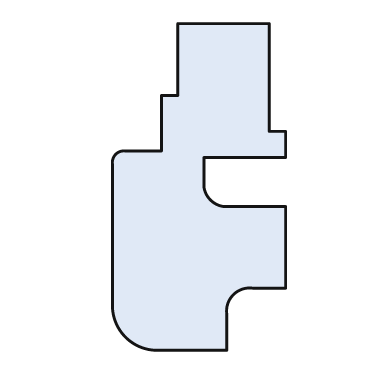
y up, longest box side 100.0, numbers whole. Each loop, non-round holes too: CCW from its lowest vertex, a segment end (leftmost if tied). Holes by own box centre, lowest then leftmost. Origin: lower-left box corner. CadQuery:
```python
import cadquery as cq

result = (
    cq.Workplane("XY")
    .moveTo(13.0, 0.0)
    .lineTo(35.0, 0.0)
    .lineTo(35.0, 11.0)
    .threePointArc((37.0, 17.0), (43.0, 19.0))
    .lineTo(53.0, 19.0)
    .lineTo(53.0, 44.0)
    .lineTo(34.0, 44.0)
    .threePointArc((30.0, 46.0), (28.0, 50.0))
    .lineTo(28.0, 59.0)
    .lineTo(53.0, 59.0)
    .lineTo(53.0, 67.0)
    .lineTo(48.0, 67.0)
    .lineTo(48.0, 100.0)
    .lineTo(20.0, 100.0)
    .lineTo(20.0, 78.0)
    .lineTo(15.0, 78.0)
    .lineTo(15.0, 61.0)
    .lineTo(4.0, 61.0)
    .threePointArc((1.0, 60.0), (0.0, 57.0))
    .lineTo(0.0, 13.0)
    .threePointArc((4.0, 4.0), (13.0, 0.0))
    .close()
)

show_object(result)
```